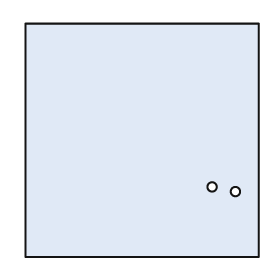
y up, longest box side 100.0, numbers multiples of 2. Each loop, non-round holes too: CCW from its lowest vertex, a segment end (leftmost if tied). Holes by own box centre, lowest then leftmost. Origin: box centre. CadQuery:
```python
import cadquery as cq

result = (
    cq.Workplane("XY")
    .moveTo(-50.0, -50.0)
    .lineTo(50.0, -50.0)
    .lineTo(50.0, 50.0)
    .lineTo(-50.0, 50.0)
    .close()
    .moveTo(40.0, -22.0)
    .circle(2.0)
    .moveTo(30.0, -20.0)
    .circle(2.0)
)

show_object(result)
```